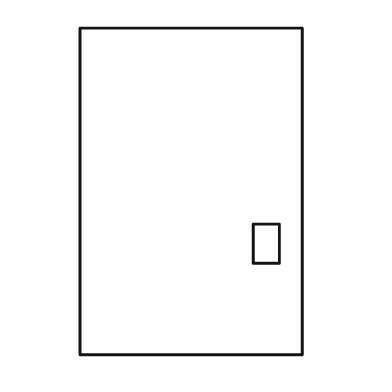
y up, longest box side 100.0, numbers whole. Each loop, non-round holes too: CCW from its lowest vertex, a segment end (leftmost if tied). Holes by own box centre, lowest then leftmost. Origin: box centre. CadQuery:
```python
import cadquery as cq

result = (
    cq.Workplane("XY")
    .moveTo(-34.0, -50.0)
    .lineTo(34.0, -50.0)
    .lineTo(34.0, 50.0)
    .lineTo(-34.0, 50.0)
    .close()
    .moveTo(19.0, -22.0)
    .lineTo(27.0, -22.0)
    .lineTo(27.0, -10.0)
    .lineTo(19.0, -10.0)
    .close()
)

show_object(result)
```